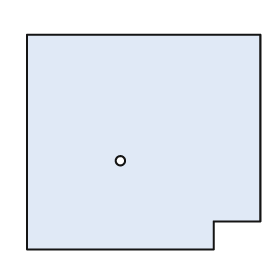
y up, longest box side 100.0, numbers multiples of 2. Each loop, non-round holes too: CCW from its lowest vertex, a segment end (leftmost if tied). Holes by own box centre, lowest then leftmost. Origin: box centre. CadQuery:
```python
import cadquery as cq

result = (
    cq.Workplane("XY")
    .moveTo(-50.0, -46.0)
    .lineTo(30.0, -46.0)
    .lineTo(30.0, -34.0)
    .lineTo(50.0, -34.0)
    .lineTo(50.0, 46.0)
    .lineTo(-50.0, 46.0)
    .close()
    .moveTo(-10.0, -8.0)
    .circle(2.0)
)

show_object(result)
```